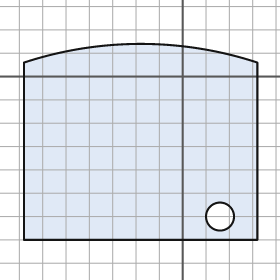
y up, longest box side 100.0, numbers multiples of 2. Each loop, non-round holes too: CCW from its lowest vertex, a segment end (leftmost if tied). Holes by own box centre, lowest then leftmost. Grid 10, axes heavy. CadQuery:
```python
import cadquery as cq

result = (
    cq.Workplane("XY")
    .moveTo(-68.0, -70.0)
    .lineTo(32.0, -70.0)
    .lineTo(32.0, 6.0)
    .threePointArc((-18.0, 14.0), (-68.0, 6.0))
    .close()
    .moveTo(16.0, -60.0)
    .circle(6.0)
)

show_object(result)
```